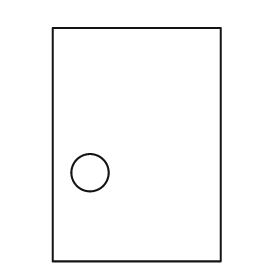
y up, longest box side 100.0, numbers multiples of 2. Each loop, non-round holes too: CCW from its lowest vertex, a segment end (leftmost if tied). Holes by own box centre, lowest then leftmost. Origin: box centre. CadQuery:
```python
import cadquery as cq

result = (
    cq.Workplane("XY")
    .moveTo(-36.0, -50.0)
    .lineTo(36.0, -50.0)
    .lineTo(36.0, 50.0)
    .lineTo(-36.0, 50.0)
    .close()
    .moveTo(-20.0, -12.0)
    .circle(8.0)
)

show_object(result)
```